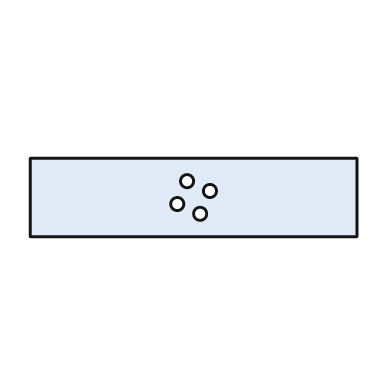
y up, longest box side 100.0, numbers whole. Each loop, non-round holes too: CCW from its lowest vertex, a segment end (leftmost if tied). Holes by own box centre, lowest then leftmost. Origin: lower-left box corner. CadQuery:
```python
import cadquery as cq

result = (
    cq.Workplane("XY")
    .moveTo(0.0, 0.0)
    .lineTo(100.0, 0.0)
    .lineTo(100.0, 24.0)
    .lineTo(0.0, 24.0)
    .close()
    .moveTo(52.0, 7.0)
    .circle(2.0)
    .moveTo(45.0, 10.0)
    .circle(2.0)
    .moveTo(55.0, 14.0)
    .circle(2.0)
    .moveTo(48.0, 17.0)
    .circle(2.0)
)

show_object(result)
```